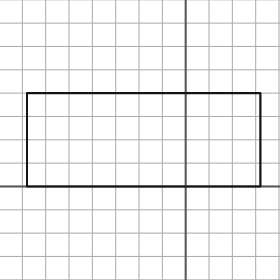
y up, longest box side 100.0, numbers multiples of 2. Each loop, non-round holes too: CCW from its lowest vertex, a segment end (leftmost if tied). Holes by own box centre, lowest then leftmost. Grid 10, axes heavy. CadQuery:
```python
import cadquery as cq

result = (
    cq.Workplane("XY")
    .moveTo(-68.0, 0.0)
    .lineTo(32.0, 0.0)
    .lineTo(32.0, 40.0)
    .lineTo(-68.0, 40.0)
    .close()
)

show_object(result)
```